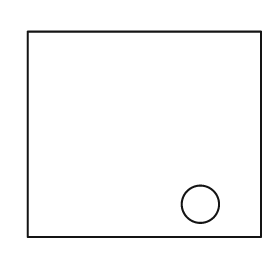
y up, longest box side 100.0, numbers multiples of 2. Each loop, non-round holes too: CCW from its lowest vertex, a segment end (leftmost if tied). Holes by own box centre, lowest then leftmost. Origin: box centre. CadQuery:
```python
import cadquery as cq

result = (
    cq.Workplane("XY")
    .moveTo(-50.0, -44.0)
    .lineTo(50.0, -44.0)
    .lineTo(50.0, 44.0)
    .lineTo(-50.0, 44.0)
    .close()
    .moveTo(24.0, -30.0)
    .circle(8.0)
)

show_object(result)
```